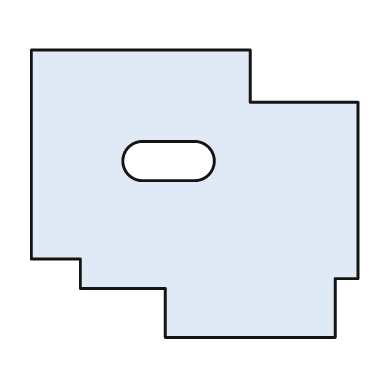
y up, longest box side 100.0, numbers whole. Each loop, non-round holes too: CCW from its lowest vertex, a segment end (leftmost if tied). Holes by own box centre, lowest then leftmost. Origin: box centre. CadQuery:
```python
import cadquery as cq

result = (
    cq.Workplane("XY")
    .moveTo(-9.0, -44.0)
    .lineTo(43.0, -44.0)
    .lineTo(43.0, -26.0)
    .lineTo(50.0, -26.0)
    .lineTo(50.0, 28.0)
    .lineTo(17.0, 28.0)
    .lineTo(17.0, 44.0)
    .lineTo(-50.0, 44.0)
    .lineTo(-50.0, -20.0)
    .lineTo(-35.0, -20.0)
    .lineTo(-35.0, -29.0)
    .lineTo(-9.0, -29.0)
    .close()
    .moveTo(-16.0, 4.0)
    .lineTo(0.0, 4.0)
    .threePointArc((6.0, 10.0), (0.0, 16.0))
    .lineTo(-16.0, 16.0)
    .threePointArc((-22.0, 10.0), (-16.0, 4.0))
    .close()
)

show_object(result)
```